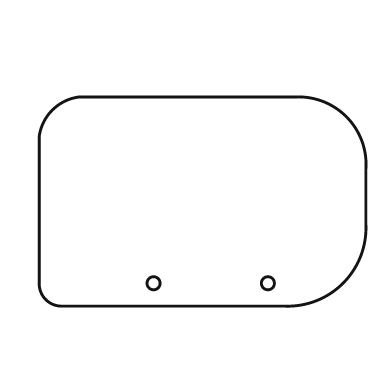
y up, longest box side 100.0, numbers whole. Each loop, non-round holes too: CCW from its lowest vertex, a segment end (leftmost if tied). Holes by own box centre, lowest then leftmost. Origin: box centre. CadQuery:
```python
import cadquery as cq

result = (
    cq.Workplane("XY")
    .moveTo(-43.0, -32.0)
    .lineTo(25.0, -32.0)
    .threePointArc((43.0, -25.0), (50.0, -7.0))
    .lineTo(50.0, 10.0)
    .threePointArc((44.0, 26.0), (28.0, 32.0))
    .lineTo(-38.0, 32.0)
    .threePointArc((-46.0, 28.0), (-50.0, 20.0))
    .lineTo(-50.0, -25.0)
    .threePointArc((-48.0, -30.0), (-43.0, -32.0))
    .close()
    .moveTo(-15.0, -25.0)
    .circle(2.0)
    .moveTo(20.0, -25.0)
    .circle(2.0)
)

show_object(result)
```